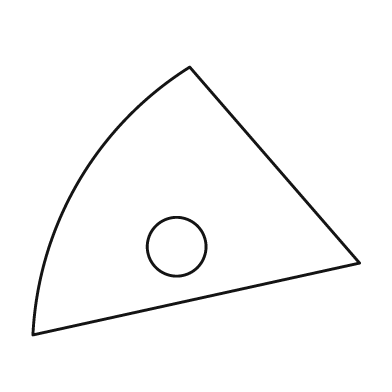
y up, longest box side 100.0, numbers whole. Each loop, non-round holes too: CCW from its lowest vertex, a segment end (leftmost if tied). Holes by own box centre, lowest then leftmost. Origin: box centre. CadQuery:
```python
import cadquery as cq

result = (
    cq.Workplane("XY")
    .moveTo(-50.0, -41.0)
    .lineTo(50.0, -19.0)
    .lineTo(-2.0, 41.0)
    .threePointArc((-36.0, 6.0), (-50.0, -41.0))
    .close()
    .moveTo(-6.0, -14.0)
    .circle(9.0)
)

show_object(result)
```